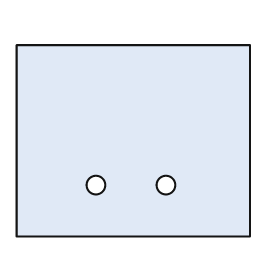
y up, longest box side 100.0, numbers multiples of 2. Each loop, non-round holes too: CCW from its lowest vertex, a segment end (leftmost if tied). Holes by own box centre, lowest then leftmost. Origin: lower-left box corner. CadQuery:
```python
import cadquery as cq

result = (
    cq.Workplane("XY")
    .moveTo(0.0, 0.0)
    .lineTo(100.0, 0.0)
    .lineTo(100.0, 82.0)
    .lineTo(0.0, 82.0)
    .close()
    .moveTo(34.0, 22.0)
    .circle(4.0)
    .moveTo(64.0, 22.0)
    .circle(4.0)
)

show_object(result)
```